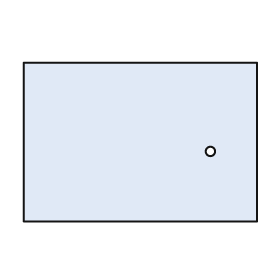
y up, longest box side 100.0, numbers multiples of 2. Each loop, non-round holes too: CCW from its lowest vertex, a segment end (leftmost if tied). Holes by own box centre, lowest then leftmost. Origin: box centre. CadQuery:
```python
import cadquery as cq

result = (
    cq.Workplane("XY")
    .moveTo(-50.0, -34.0)
    .lineTo(50.0, -34.0)
    .lineTo(50.0, 34.0)
    .lineTo(-50.0, 34.0)
    .close()
    .moveTo(30.0, -4.0)
    .circle(2.0)
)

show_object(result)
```